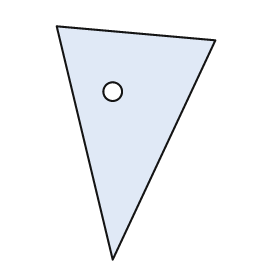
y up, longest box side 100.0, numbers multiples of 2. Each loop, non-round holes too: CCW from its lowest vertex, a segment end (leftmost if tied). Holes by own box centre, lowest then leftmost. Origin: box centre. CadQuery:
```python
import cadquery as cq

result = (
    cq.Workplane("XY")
    .moveTo(-10.0, -50.0)
    .lineTo(34.0, 44.0)
    .lineTo(-34.0, 50.0)
    .close()
    .moveTo(-10.0, 22.0)
    .circle(4.0)
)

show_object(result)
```